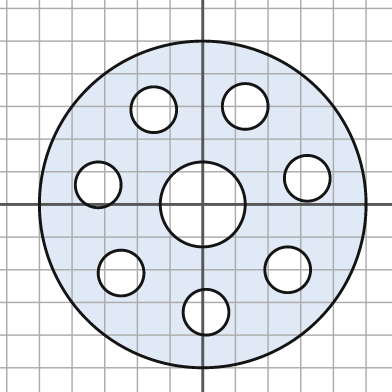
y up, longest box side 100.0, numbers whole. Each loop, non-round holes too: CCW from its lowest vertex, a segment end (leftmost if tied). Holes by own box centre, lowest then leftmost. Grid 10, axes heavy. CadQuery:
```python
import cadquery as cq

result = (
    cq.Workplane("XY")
    .moveTo(0.0, 0.0)
    .circle(50.0)
    .moveTo(1.0, -33.0)
    .circle(7.0)
    .moveTo(-25.0, -21.0)
    .circle(7.0)
    .moveTo(26.0, -20.0)
    .circle(7.0)
    .moveTo(0.0, 0.0)
    .circle(13.0)
    .moveTo(-32.0, 6.0)
    .circle(7.0)
    .moveTo(32.0, 8.0)
    .circle(7.0)
    .moveTo(-15.0, 29.0)
    .circle(7.0)
    .moveTo(13.0, 30.0)
    .circle(7.0)
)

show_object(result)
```